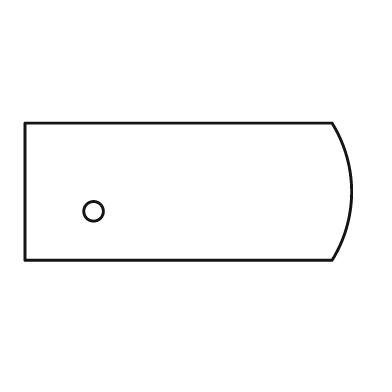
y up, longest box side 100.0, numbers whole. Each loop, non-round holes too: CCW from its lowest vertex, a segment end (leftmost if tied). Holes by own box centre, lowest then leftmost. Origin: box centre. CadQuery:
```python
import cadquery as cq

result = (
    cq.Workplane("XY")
    .moveTo(-50.0, -21.0)
    .lineTo(44.0, -21.0)
    .threePointArc((50.0, 0.0), (44.0, 21.0))
    .lineTo(-50.0, 21.0)
    .close()
    .moveTo(-29.0, -6.0)
    .circle(3.0)
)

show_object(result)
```